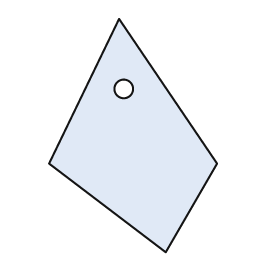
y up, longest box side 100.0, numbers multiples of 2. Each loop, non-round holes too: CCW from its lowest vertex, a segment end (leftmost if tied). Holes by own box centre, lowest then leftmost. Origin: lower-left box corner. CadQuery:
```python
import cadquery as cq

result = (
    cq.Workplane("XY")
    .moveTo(50.0, 0.0)
    .lineTo(72.0, 38.0)
    .lineTo(30.0, 100.0)
    .lineTo(0.0, 38.0)
    .close()
    .moveTo(32.0, 70.0)
    .circle(4.0)
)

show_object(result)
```